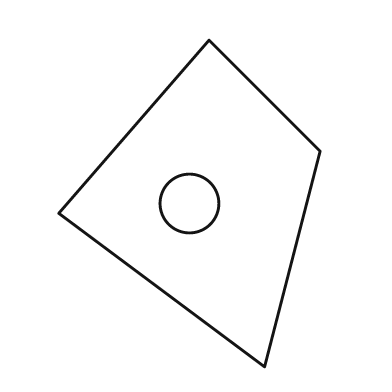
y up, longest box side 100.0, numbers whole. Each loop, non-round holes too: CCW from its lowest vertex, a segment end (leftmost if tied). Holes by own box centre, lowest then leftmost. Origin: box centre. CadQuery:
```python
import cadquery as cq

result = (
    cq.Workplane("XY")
    .moveTo(23.0, -50.0)
    .lineTo(40.0, 16.0)
    .lineTo(6.0, 50.0)
    .lineTo(-40.0, -3.0)
    .close()
    .moveTo(0.0, 0.0)
    .circle(9.0)
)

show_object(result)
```